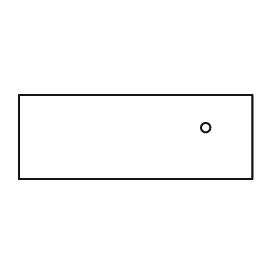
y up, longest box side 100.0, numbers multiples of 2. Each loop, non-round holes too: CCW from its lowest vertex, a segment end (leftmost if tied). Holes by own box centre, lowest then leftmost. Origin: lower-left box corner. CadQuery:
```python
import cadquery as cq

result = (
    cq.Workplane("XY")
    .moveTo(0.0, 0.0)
    .lineTo(100.0, 0.0)
    .lineTo(100.0, 36.0)
    .lineTo(0.0, 36.0)
    .close()
    .moveTo(80.0, 22.0)
    .circle(2.0)
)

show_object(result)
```